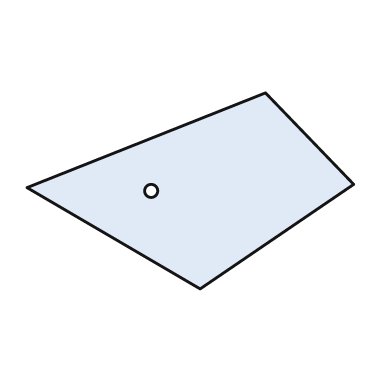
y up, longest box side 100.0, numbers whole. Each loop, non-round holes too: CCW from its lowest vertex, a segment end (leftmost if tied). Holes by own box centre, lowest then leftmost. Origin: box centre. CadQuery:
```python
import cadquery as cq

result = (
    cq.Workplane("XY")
    .moveTo(3.0, -30.0)
    .lineTo(50.0, 2.0)
    .lineTo(23.0, 30.0)
    .lineTo(-50.0, 1.0)
    .close()
    .moveTo(-12.0, 0.0)
    .circle(2.0)
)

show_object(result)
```